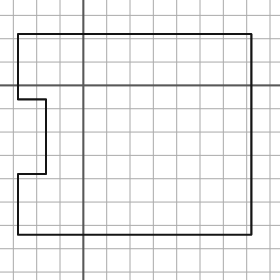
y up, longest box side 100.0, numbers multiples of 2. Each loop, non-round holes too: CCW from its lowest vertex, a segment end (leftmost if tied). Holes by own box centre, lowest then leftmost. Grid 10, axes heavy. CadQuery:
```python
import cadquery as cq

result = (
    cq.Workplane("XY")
    .moveTo(-28.0, -64.0)
    .lineTo(72.0, -64.0)
    .lineTo(72.0, 22.0)
    .lineTo(-28.0, 22.0)
    .lineTo(-28.0, -6.0)
    .lineTo(-16.0, -6.0)
    .lineTo(-16.0, -38.0)
    .lineTo(-28.0, -38.0)
    .close()
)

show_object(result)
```